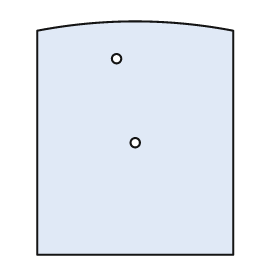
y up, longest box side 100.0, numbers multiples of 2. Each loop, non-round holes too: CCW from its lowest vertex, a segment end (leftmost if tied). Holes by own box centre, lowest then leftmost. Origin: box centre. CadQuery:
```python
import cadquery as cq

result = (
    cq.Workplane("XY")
    .moveTo(-42.0, -50.0)
    .lineTo(42.0, -50.0)
    .lineTo(42.0, 46.0)
    .threePointArc((0.0, 50.0), (-42.0, 46.0))
    .close()
    .moveTo(0.0, -2.0)
    .circle(2.0)
    .moveTo(-8.0, 34.0)
    .circle(2.0)
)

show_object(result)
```